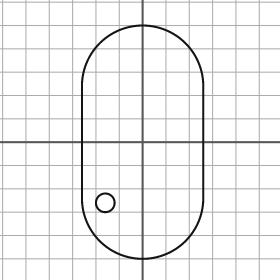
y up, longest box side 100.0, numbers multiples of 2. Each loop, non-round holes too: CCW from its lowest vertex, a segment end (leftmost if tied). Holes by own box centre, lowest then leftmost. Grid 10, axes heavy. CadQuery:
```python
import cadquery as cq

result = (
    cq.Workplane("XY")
    .moveTo(-26.0, -24.0)
    .threePointArc((0.0, -50.0), (26.0, -24.0))
    .lineTo(26.0, 24.0)
    .threePointArc((0.0, 50.0), (-26.0, 24.0))
    .close()
    .moveTo(-16.0, -26.0)
    .circle(4.0)
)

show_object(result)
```